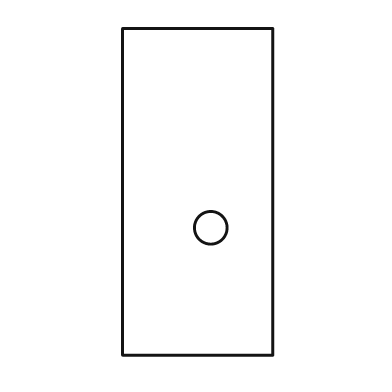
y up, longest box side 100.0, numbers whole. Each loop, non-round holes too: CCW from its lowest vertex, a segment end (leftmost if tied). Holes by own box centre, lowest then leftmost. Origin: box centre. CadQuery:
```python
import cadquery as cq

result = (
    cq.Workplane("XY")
    .moveTo(-23.0, -50.0)
    .lineTo(23.0, -50.0)
    .lineTo(23.0, 50.0)
    .lineTo(-23.0, 50.0)
    .close()
    .moveTo(4.0, -11.0)
    .circle(5.0)
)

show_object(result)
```